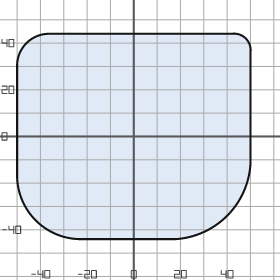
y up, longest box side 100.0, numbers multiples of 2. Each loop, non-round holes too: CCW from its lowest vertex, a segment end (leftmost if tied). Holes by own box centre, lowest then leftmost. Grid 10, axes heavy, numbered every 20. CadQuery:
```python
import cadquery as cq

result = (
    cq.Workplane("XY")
    .moveTo(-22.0, -44.0)
    .lineTo(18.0, -44.0)
    .threePointArc((40.0, -34.0), (50.0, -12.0))
    .lineTo(50.0, 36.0)
    .threePointArc((48.0, 42.0), (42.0, 44.0))
    .lineTo(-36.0, 44.0)
    .threePointArc((-46.0, 40.0), (-50.0, 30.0))
    .lineTo(-50.0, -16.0)
    .threePointArc((-42.0, -36.0), (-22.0, -44.0))
    .close()
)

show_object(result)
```